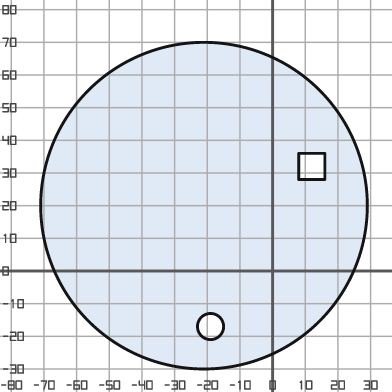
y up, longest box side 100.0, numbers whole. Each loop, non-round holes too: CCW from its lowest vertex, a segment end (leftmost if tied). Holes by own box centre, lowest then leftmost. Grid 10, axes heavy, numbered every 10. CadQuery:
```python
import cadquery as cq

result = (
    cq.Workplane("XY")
    .moveTo(-21.0, 20.0)
    .circle(50.0)
    .moveTo(-19.0, -17.0)
    .circle(4.0)
    .moveTo(8.0, 28.0)
    .lineTo(16.0, 28.0)
    .lineTo(16.0, 36.0)
    .lineTo(8.0, 36.0)
    .close()
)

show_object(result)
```